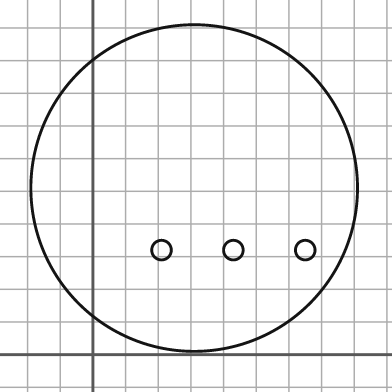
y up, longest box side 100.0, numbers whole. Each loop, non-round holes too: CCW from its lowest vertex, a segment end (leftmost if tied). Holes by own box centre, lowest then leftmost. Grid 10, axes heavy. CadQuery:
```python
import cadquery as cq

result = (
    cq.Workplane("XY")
    .moveTo(31.0, 51.0)
    .circle(50.0)
    .moveTo(21.0, 32.0)
    .circle(3.0)
    .moveTo(43.0, 32.0)
    .circle(3.0)
    .moveTo(65.0, 32.0)
    .circle(3.0)
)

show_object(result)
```